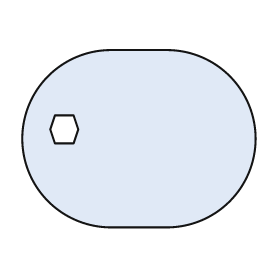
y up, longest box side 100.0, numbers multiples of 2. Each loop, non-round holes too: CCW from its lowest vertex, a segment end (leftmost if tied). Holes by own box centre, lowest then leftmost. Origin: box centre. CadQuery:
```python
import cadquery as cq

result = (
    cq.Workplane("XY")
    .moveTo(-12.0, -38.0)
    .lineTo(12.0, -38.0)
    .threePointArc((50.0, 0.0), (12.0, 38.0))
    .lineTo(-12.0, 38.0)
    .threePointArc((-50.0, 0.0), (-12.0, -38.0))
    .close()
    .moveTo(-36.0, -2.0)
    .lineTo(-28.0, -2.0)
    .lineTo(-26.0, 4.0)
    .lineTo(-28.0, 10.0)
    .lineTo(-36.0, 10.0)
    .lineTo(-38.0, 4.0)
    .close()
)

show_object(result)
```